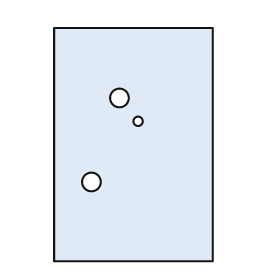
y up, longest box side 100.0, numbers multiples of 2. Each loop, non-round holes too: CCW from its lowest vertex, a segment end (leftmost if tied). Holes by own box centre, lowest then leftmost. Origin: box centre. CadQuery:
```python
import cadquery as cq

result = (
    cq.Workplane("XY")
    .moveTo(-34.0, -50.0)
    .lineTo(34.0, -50.0)
    .lineTo(34.0, 50.0)
    .lineTo(-34.0, 50.0)
    .close()
    .moveTo(-18.0, -16.0)
    .circle(4.0)
    .moveTo(2.0, 10.0)
    .circle(2.0)
    .moveTo(-6.0, 20.0)
    .circle(4.0)
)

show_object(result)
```